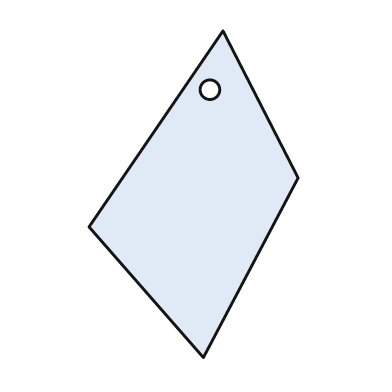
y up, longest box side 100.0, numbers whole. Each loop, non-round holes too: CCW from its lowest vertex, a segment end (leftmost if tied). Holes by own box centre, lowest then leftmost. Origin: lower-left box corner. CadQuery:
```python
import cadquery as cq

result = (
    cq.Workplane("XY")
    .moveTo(35.0, 0.0)
    .lineTo(64.0, 55.0)
    .lineTo(41.0, 100.0)
    .lineTo(0.0, 40.0)
    .close()
    .moveTo(37.0, 82.0)
    .circle(3.0)
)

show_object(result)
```